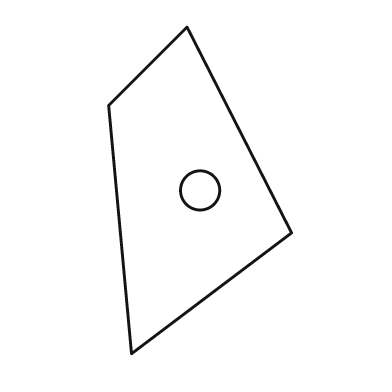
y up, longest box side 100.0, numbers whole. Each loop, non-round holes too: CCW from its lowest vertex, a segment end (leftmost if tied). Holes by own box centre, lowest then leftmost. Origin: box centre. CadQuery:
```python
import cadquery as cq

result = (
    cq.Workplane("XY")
    .moveTo(-21.0, -50.0)
    .lineTo(28.0, -13.0)
    .lineTo(-4.0, 50.0)
    .lineTo(-28.0, 26.0)
    .close()
    .moveTo(0.0, 0.0)
    .circle(6.0)
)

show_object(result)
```